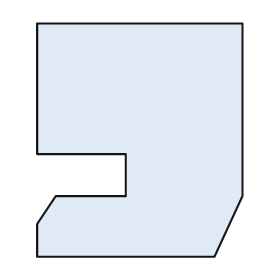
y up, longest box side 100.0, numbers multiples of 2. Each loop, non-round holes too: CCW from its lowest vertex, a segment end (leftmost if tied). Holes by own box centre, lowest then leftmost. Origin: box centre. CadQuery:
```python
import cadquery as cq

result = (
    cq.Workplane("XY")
    .moveTo(-44.0, -50.0)
    .lineTo(32.0, -50.0)
    .lineTo(44.0, -24.0)
    .lineTo(44.0, 50.0)
    .lineTo(-44.0, 50.0)
    .lineTo(-44.0, -6.0)
    .lineTo(-6.0, -6.0)
    .lineTo(-6.0, -24.0)
    .lineTo(-36.0, -24.0)
    .lineTo(-44.0, -36.0)
    .close()
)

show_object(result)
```